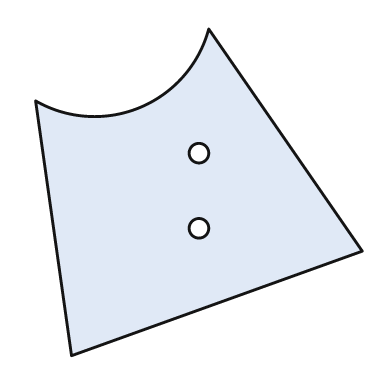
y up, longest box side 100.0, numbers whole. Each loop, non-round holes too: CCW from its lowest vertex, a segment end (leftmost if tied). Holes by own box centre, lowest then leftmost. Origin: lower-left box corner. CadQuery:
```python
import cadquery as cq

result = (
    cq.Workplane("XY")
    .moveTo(11.0, 0.0)
    .lineTo(100.0, 32.0)
    .lineTo(53.0, 100.0)
    .threePointArc((32.0, 76.0), (0.0, 78.0))
    .close()
    .moveTo(50.0, 39.0)
    .circle(3.0)
    .moveTo(50.0, 62.0)
    .circle(3.0)
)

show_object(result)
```